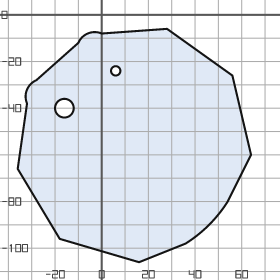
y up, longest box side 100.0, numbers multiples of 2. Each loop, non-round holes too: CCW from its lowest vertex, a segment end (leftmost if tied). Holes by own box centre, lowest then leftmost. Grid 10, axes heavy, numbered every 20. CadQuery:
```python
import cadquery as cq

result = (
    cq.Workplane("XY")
    .moveTo(16.0, -106.0)
    .lineTo(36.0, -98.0)
    .threePointArc((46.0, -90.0), (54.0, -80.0))
    .lineTo(64.0, -60.0)
    .lineTo(56.0, -26.0)
    .lineTo(28.0, -6.0)
    .lineTo(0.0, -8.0)
    .threePointArc((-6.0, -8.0), (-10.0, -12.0))
    .lineTo(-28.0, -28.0)
    .threePointArc((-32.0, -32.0), (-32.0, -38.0))
    .lineTo(-36.0, -66.0)
    .lineTo(-18.0, -96.0)
    .close()
    .moveTo(-16.0, -40.0)
    .circle(4.0)
    .moveTo(6.0, -24.0)
    .circle(2.0)
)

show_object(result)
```